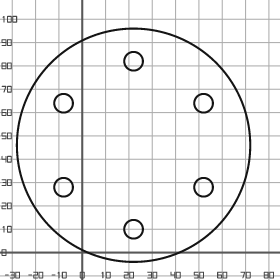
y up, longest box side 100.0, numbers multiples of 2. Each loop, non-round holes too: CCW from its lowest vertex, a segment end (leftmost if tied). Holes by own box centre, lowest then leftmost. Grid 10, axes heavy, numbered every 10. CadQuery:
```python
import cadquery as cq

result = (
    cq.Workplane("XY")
    .moveTo(22.0, 46.0)
    .circle(50.0)
    .moveTo(22.0, 10.0)
    .circle(4.0)
    .moveTo(-8.0, 28.0)
    .circle(4.0)
    .moveTo(52.0, 28.0)
    .circle(4.0)
    .moveTo(-8.0, 64.0)
    .circle(4.0)
    .moveTo(52.0, 64.0)
    .circle(4.0)
    .moveTo(22.0, 82.0)
    .circle(4.0)
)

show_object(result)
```